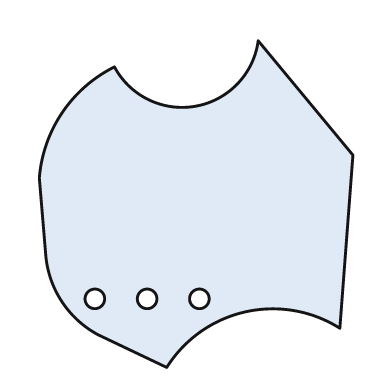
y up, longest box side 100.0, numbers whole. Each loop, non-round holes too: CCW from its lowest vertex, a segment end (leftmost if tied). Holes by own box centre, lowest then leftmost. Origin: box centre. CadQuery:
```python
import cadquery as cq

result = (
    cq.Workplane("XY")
    .moveTo(-9.0, -50.0)
    .threePointArc((15.0, -33.0), (44.0, -38.0))
    .lineTo(48.0, 15.0)
    .lineTo(19.0, 50.0)
    .threePointArc((0.0, 30.0), (-25.0, 42.0))
    .threePointArc((-41.0, 28.0), (-48.0, 8.0))
    .lineTo(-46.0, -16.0)
    .threePointArc((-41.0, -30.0), (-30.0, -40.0))
    .close()
    .moveTo(-31.0, -29.0)
    .circle(3.0)
    .moveTo(-15.0, -29.0)
    .circle(3.0)
    .moveTo(1.0, -29.0)
    .circle(3.0)
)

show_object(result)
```